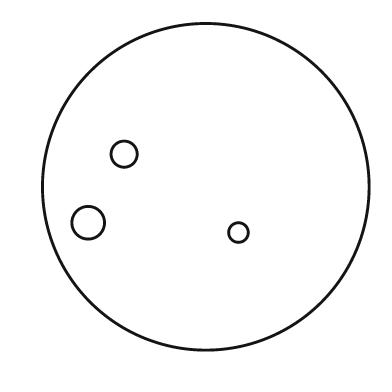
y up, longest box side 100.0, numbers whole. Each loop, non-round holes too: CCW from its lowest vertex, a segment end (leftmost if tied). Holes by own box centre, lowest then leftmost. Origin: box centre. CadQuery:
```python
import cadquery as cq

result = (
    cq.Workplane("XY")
    .moveTo(0.0, 0.0)
    .circle(50.0)
    .moveTo(10.0, -14.0)
    .circle(3.0)
    .moveTo(-36.0, -11.0)
    .circle(5.0)
    .moveTo(-25.0, 10.0)
    .circle(4.0)
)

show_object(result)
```